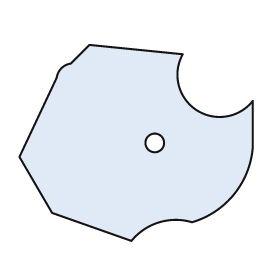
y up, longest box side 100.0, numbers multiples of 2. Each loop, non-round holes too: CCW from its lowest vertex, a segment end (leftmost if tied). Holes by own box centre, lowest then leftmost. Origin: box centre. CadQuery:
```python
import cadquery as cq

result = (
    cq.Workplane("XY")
    .moveTo(-2.0, -42.0)
    .threePointArc((10.0, -34.0), (24.0, -34.0))
    .threePointArc((42.0, -22.0), (50.0, -2.0))
    .lineTo(50.0, 18.0)
    .threePointArc((26.0, 14.0), (20.0, 38.0))
    .lineTo(-20.0, 42.0)
    .lineTo(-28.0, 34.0)
    .threePointArc((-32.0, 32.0), (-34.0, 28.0))
    .lineTo(-50.0, -6.0)
    .lineTo(-36.0, -30.0)
    .close()
    .moveTo(8.0, 0.0)
    .circle(4.0)
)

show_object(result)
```